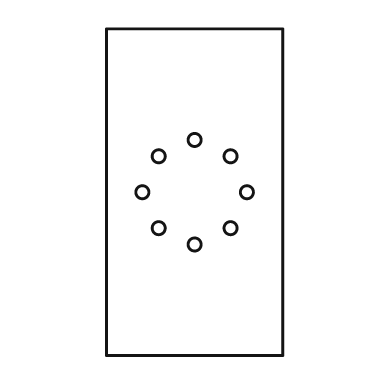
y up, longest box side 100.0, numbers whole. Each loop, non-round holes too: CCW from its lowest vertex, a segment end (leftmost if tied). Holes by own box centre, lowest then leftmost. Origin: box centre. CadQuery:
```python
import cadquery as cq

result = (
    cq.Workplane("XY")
    .moveTo(-27.0, -50.0)
    .lineTo(27.0, -50.0)
    .lineTo(27.0, 50.0)
    .lineTo(-27.0, 50.0)
    .close()
    .moveTo(0.0, -16.0)
    .circle(2.0)
    .moveTo(-11.0, -11.0)
    .circle(2.0)
    .moveTo(11.0, -11.0)
    .circle(2.0)
    .moveTo(-16.0, 0.0)
    .circle(2.0)
    .moveTo(16.0, 0.0)
    .circle(2.0)
    .moveTo(-11.0, 11.0)
    .circle(2.0)
    .moveTo(11.0, 11.0)
    .circle(2.0)
    .moveTo(0.0, 16.0)
    .circle(2.0)
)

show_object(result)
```